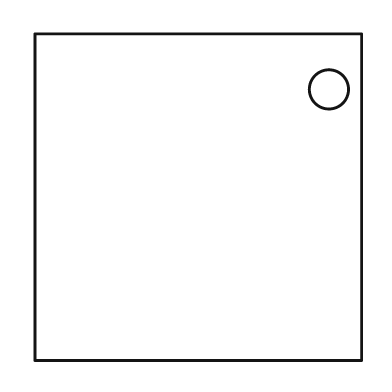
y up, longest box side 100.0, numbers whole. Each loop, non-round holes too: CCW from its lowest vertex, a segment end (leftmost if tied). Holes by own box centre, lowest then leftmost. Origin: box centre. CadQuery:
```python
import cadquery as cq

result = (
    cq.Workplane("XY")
    .moveTo(-50.0, -50.0)
    .lineTo(50.0, -50.0)
    .lineTo(50.0, 50.0)
    .lineTo(-50.0, 50.0)
    .close()
    .moveTo(40.0, 33.0)
    .circle(6.0)
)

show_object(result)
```